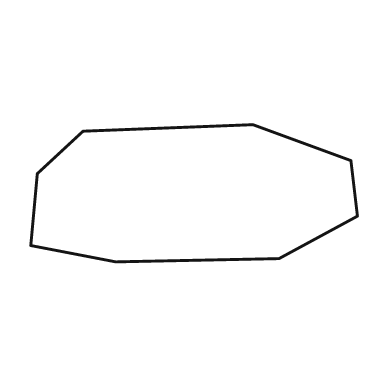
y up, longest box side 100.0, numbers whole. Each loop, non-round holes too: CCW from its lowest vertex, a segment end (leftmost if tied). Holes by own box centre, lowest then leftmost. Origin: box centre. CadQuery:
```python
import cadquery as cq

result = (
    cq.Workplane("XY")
    .moveTo(-24.0, -21.0)
    .lineTo(26.0, -20.0)
    .lineTo(50.0, -7.0)
    .lineTo(48.0, 10.0)
    .lineTo(18.0, 21.0)
    .lineTo(-34.0, 19.0)
    .lineTo(-48.0, 6.0)
    .lineTo(-50.0, -16.0)
    .close()
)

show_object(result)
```